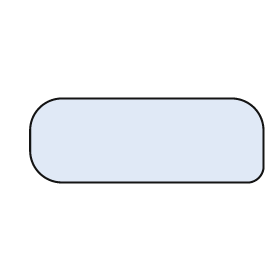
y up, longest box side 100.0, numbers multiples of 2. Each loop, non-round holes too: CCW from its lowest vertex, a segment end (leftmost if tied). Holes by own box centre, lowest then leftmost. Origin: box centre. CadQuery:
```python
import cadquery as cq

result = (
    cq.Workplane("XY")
    .moveTo(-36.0, -18.0)
    .lineTo(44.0, -18.0)
    .threePointArc((48.0, -16.0), (50.0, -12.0))
    .lineTo(50.0, 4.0)
    .threePointArc((46.0, 14.0), (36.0, 18.0))
    .lineTo(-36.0, 18.0)
    .threePointArc((-46.0, 14.0), (-50.0, 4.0))
    .lineTo(-50.0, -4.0)
    .threePointArc((-46.0, -14.0), (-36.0, -18.0))
    .close()
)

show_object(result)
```